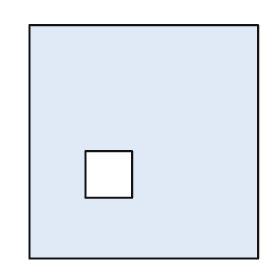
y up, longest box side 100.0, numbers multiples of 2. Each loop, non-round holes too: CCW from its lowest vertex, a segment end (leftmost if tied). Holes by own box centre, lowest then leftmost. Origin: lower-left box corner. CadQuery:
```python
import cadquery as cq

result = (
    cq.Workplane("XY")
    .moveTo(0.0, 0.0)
    .lineTo(98.0, 0.0)
    .lineTo(98.0, 100.0)
    .lineTo(0.0, 100.0)
    .close()
    .moveTo(24.0, 26.0)
    .lineTo(44.0, 26.0)
    .lineTo(44.0, 46.0)
    .lineTo(24.0, 46.0)
    .close()
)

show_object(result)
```